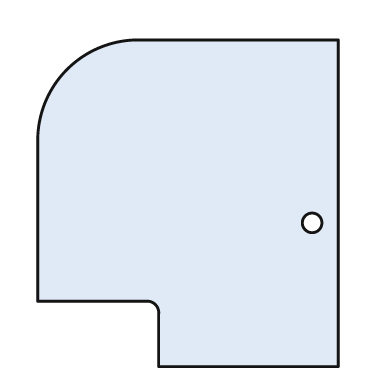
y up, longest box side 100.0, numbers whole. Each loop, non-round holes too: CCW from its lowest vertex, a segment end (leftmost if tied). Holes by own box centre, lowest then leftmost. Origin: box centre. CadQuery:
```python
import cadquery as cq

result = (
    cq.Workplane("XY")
    .moveTo(-9.0, -50.0)
    .lineTo(46.0, -50.0)
    .lineTo(46.0, 50.0)
    .lineTo(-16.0, 50.0)
    .threePointArc((-37.0, 41.0), (-46.0, 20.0))
    .lineTo(-46.0, -30.0)
    .lineTo(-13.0, -30.0)
    .threePointArc((-10.0, -31.0), (-9.0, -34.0))
    .close()
    .moveTo(38.0, -6.0)
    .circle(3.0)
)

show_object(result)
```